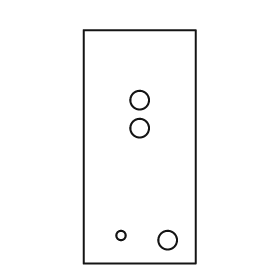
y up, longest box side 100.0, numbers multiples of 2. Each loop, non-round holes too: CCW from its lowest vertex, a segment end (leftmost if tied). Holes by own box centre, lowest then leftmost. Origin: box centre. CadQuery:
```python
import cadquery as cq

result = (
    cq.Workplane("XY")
    .moveTo(-24.0, -50.0)
    .lineTo(24.0, -50.0)
    .lineTo(24.0, 50.0)
    .lineTo(-24.0, 50.0)
    .close()
    .moveTo(12.0, -40.0)
    .circle(4.0)
    .moveTo(-8.0, -38.0)
    .circle(2.0)
    .moveTo(0.0, 8.0)
    .circle(4.0)
    .moveTo(0.0, 20.0)
    .circle(4.0)
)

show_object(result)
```